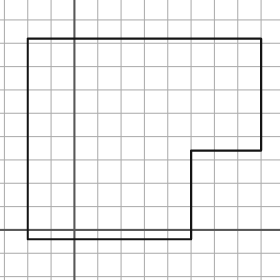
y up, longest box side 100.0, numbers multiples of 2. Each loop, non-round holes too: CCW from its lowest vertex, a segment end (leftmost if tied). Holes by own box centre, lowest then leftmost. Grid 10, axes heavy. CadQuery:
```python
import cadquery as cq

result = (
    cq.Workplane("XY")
    .moveTo(-20.0, -4.0)
    .lineTo(50.0, -4.0)
    .lineTo(50.0, 34.0)
    .lineTo(80.0, 34.0)
    .lineTo(80.0, 82.0)
    .lineTo(-20.0, 82.0)
    .close()
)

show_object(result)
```